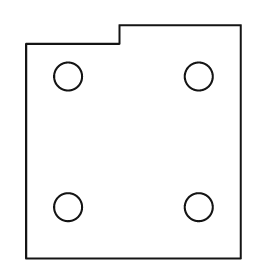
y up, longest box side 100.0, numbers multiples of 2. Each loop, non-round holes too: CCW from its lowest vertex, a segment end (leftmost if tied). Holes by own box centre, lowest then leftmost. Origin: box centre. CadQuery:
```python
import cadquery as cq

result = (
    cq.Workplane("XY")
    .moveTo(-46.0, -50.0)
    .lineTo(46.0, -50.0)
    .lineTo(46.0, 50.0)
    .lineTo(-6.0, 50.0)
    .lineTo(-6.0, 42.0)
    .lineTo(-46.0, 42.0)
    .close()
    .moveTo(-28.0, -28.0)
    .circle(6.0)
    .moveTo(28.0, -28.0)
    .circle(6.0)
    .moveTo(-28.0, 28.0)
    .circle(6.0)
    .moveTo(28.0, 28.0)
    .circle(6.0)
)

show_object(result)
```